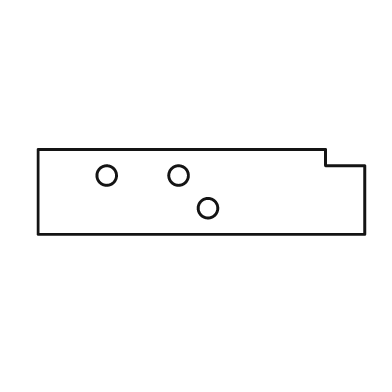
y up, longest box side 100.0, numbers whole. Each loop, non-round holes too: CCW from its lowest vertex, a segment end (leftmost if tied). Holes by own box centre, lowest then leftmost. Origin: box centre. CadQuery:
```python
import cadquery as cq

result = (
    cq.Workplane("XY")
    .moveTo(-50.0, -13.0)
    .lineTo(50.0, -13.0)
    .lineTo(50.0, 8.0)
    .lineTo(38.0, 8.0)
    .lineTo(38.0, 13.0)
    .lineTo(-50.0, 13.0)
    .close()
    .moveTo(2.0, -5.0)
    .circle(3.0)
    .moveTo(-29.0, 5.0)
    .circle(3.0)
    .moveTo(-7.0, 5.0)
    .circle(3.0)
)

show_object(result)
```